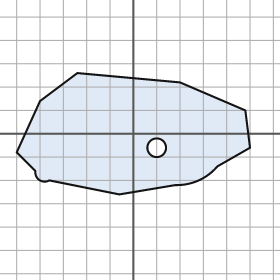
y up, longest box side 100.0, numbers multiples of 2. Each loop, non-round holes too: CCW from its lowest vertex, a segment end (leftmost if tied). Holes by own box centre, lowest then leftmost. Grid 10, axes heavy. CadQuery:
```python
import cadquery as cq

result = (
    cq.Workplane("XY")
    .moveTo(-6.0, -26.0)
    .lineTo(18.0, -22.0)
    .threePointArc((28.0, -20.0), (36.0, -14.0))
    .lineTo(50.0, -6.0)
    .lineTo(48.0, 10.0)
    .lineTo(20.0, 22.0)
    .lineTo(-24.0, 26.0)
    .lineTo(-40.0, 14.0)
    .lineTo(-50.0, -8.0)
    .lineTo(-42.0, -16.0)
    .threePointArc((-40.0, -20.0), (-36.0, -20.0))
    .close()
    .moveTo(10.0, -6.0)
    .circle(4.0)
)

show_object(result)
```